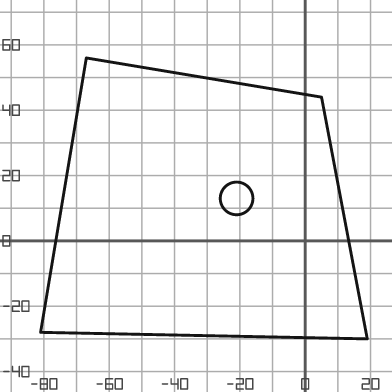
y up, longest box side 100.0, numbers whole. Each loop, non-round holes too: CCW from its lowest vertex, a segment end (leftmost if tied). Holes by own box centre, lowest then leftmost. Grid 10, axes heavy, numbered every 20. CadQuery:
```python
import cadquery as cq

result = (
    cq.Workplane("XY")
    .moveTo(19.0, -30.0)
    .lineTo(5.0, 44.0)
    .lineTo(-67.0, 56.0)
    .lineTo(-81.0, -28.0)
    .close()
    .moveTo(-21.0, 13.0)
    .circle(5.0)
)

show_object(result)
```